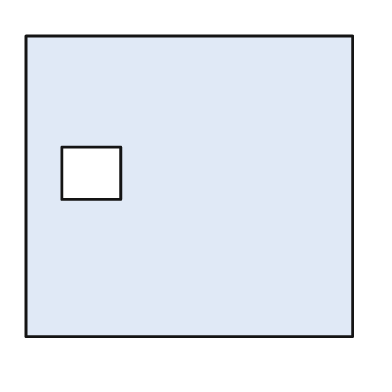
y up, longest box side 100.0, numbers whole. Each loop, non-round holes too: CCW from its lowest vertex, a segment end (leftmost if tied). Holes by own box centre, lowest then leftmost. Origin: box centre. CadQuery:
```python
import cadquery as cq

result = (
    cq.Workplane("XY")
    .moveTo(-50.0, -46.0)
    .lineTo(50.0, -46.0)
    .lineTo(50.0, 46.0)
    .lineTo(-50.0, 46.0)
    .close()
    .moveTo(-39.0, -4.0)
    .lineTo(-21.0, -4.0)
    .lineTo(-21.0, 12.0)
    .lineTo(-39.0, 12.0)
    .close()
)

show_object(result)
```